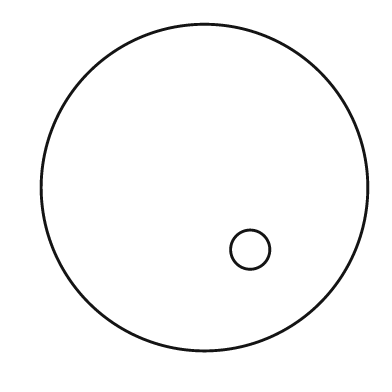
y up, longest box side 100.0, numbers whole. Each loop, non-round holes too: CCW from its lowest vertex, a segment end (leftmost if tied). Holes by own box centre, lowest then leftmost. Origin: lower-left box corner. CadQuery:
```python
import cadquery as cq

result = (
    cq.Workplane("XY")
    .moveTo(50.0, 50.0)
    .circle(50.0)
    .moveTo(64.0, 31.0)
    .circle(6.0)
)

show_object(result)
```